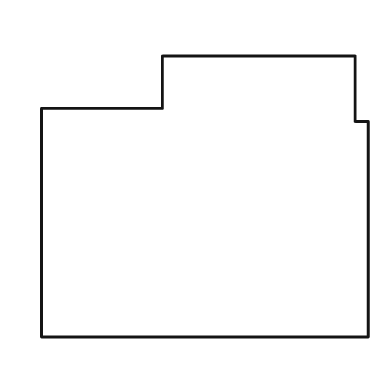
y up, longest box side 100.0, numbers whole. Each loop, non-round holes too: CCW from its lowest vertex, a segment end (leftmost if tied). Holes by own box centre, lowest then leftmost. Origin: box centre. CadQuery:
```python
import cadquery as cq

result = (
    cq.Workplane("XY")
    .moveTo(-50.0, -43.0)
    .lineTo(50.0, -43.0)
    .lineTo(50.0, 23.0)
    .lineTo(46.0, 23.0)
    .lineTo(46.0, 43.0)
    .lineTo(-13.0, 43.0)
    .lineTo(-13.0, 27.0)
    .lineTo(-50.0, 27.0)
    .close()
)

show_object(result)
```